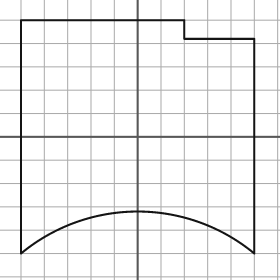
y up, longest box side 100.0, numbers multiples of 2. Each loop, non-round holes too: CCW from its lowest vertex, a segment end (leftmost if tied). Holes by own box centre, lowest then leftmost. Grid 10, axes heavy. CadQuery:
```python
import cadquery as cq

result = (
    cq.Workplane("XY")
    .moveTo(-50.0, -50.0)
    .threePointArc((0.0, -32.0), (50.0, -50.0))
    .lineTo(50.0, 42.0)
    .lineTo(20.0, 42.0)
    .lineTo(20.0, 50.0)
    .lineTo(-50.0, 50.0)
    .close()
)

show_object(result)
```